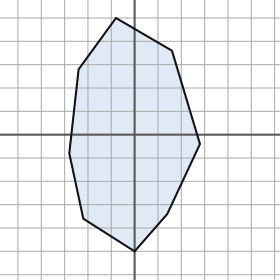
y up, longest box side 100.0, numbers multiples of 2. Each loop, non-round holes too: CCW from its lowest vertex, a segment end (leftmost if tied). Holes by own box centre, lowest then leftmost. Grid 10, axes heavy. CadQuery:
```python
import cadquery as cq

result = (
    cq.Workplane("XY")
    .moveTo(0.0, -50.0)
    .lineTo(14.0, -34.0)
    .lineTo(28.0, -4.0)
    .lineTo(16.0, 36.0)
    .lineTo(-8.0, 50.0)
    .lineTo(-24.0, 28.0)
    .lineTo(-28.0, -8.0)
    .lineTo(-22.0, -36.0)
    .close()
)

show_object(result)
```